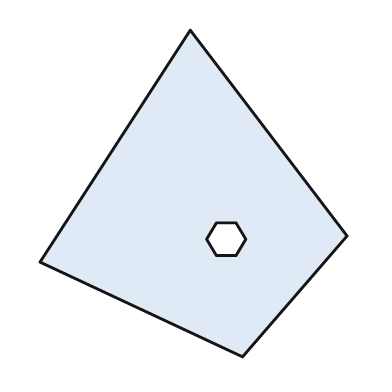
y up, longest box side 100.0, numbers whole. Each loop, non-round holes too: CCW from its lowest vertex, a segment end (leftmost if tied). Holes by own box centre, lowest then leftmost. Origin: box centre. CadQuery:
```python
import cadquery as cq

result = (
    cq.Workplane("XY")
    .moveTo(15.0, -50.0)
    .lineTo(47.0, -13.0)
    .lineTo(-1.0, 50.0)
    .lineTo(-47.0, -21.0)
    .close()
    .moveTo(7.0, -19.0)
    .lineTo(13.0, -19.0)
    .lineTo(16.0, -14.0)
    .lineTo(13.0, -9.0)
    .lineTo(7.0, -9.0)
    .lineTo(4.0, -14.0)
    .close()
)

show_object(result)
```